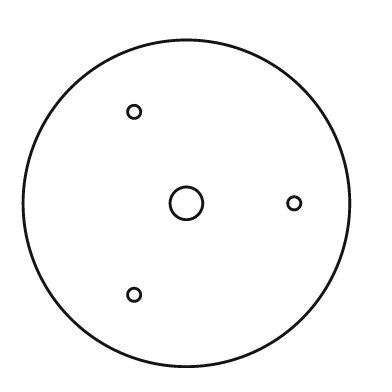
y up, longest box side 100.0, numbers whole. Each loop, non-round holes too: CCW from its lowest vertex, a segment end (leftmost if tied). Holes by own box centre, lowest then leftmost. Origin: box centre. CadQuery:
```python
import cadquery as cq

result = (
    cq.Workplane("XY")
    .moveTo(0.0, 0.0)
    .circle(50.0)
    .moveTo(-16.0, -28.0)
    .circle(2.0)
    .moveTo(0.0, 0.0)
    .circle(5.0)
    .moveTo(33.0, 0.0)
    .circle(2.0)
    .moveTo(-16.0, 28.0)
    .circle(2.0)
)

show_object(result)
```